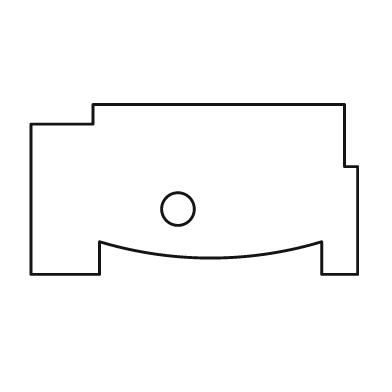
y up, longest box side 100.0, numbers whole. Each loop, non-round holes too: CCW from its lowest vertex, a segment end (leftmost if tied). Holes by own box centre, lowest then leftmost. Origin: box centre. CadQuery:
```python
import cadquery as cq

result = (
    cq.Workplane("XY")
    .moveTo(-50.0, -26.0)
    .lineTo(-29.0, -26.0)
    .lineTo(-29.0, -16.0)
    .threePointArc((5.0, -21.0), (39.0, -16.0))
    .lineTo(39.0, -26.0)
    .lineTo(50.0, -26.0)
    .lineTo(50.0, 7.0)
    .lineTo(46.0, 7.0)
    .lineTo(46.0, 26.0)
    .lineTo(-31.0, 26.0)
    .lineTo(-31.0, 20.0)
    .lineTo(-50.0, 20.0)
    .close()
    .moveTo(-5.0, -6.0)
    .circle(5.0)
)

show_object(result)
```